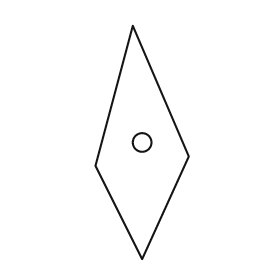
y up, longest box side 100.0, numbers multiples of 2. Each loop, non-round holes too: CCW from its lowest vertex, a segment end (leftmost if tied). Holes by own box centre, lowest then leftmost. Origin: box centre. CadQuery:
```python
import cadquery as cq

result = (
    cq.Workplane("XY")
    .moveTo(0.0, -50.0)
    .lineTo(20.0, -6.0)
    .lineTo(-4.0, 50.0)
    .lineTo(-20.0, -10.0)
    .close()
    .moveTo(0.0, 0.0)
    .circle(4.0)
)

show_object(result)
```